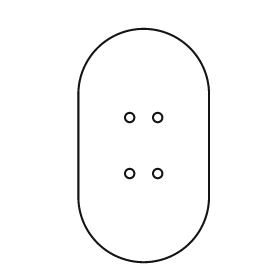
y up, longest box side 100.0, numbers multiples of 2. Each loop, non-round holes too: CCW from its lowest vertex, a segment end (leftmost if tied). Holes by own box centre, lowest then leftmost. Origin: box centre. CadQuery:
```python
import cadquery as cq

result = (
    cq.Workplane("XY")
    .moveTo(-28.0, -22.0)
    .threePointArc((0.0, -50.0), (28.0, -22.0))
    .lineTo(28.0, 22.0)
    .threePointArc((0.0, 50.0), (-28.0, 22.0))
    .close()
    .moveTo(-6.0, -12.0)
    .circle(2.0)
    .moveTo(6.0, -12.0)
    .circle(2.0)
    .moveTo(-6.0, 12.0)
    .circle(2.0)
    .moveTo(6.0, 12.0)
    .circle(2.0)
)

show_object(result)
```